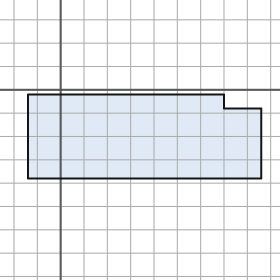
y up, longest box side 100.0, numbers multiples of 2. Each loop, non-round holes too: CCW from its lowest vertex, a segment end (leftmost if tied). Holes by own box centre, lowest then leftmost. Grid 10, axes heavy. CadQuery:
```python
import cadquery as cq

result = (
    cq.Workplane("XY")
    .moveTo(-14.0, -38.0)
    .lineTo(86.0, -38.0)
    .lineTo(86.0, -8.0)
    .lineTo(70.0, -8.0)
    .lineTo(70.0, -2.0)
    .lineTo(-14.0, -2.0)
    .close()
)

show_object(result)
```